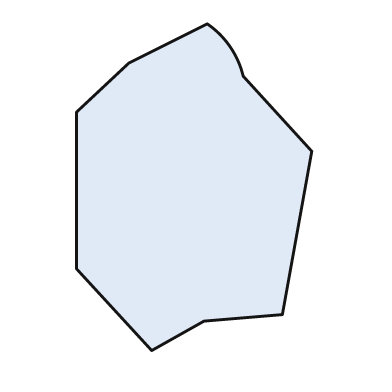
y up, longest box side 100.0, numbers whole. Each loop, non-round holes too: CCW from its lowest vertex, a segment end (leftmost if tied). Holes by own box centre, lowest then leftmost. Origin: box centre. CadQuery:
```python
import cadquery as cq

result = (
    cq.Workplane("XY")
    .moveTo(-13.0, -50.0)
    .lineTo(3.0, -41.0)
    .lineTo(27.0, -39.0)
    .lineTo(36.0, 11.0)
    .lineTo(15.0, 34.0)
    .threePointArc((11.0, 43.0), (4.0, 50.0))
    .lineTo(-20.0, 38.0)
    .lineTo(-36.0, 23.0)
    .lineTo(-36.0, -25.0)
    .close()
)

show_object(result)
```